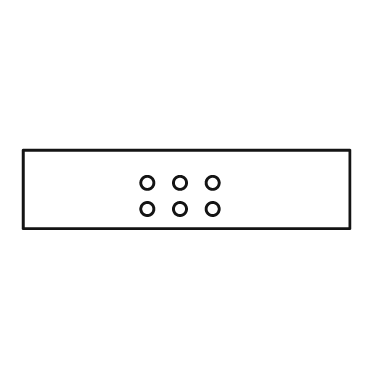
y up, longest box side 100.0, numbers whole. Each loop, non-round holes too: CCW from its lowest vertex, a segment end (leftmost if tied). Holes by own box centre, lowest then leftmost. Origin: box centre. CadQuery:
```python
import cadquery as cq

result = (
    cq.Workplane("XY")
    .moveTo(-50.0, -12.0)
    .lineTo(50.0, -12.0)
    .lineTo(50.0, 12.0)
    .lineTo(-50.0, 12.0)
    .close()
    .moveTo(-12.0, -6.0)
    .circle(2.0)
    .moveTo(-2.0, -6.0)
    .circle(2.0)
    .moveTo(8.0, -6.0)
    .circle(2.0)
    .moveTo(-12.0, 2.0)
    .circle(2.0)
    .moveTo(-2.0, 2.0)
    .circle(2.0)
    .moveTo(8.0, 2.0)
    .circle(2.0)
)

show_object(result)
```